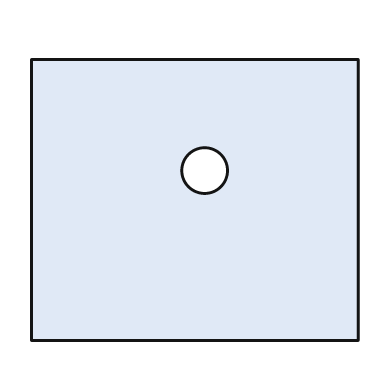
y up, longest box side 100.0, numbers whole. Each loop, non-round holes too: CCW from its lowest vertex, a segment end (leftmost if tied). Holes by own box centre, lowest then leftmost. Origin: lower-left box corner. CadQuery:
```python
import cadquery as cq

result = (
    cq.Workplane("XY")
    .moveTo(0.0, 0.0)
    .lineTo(100.0, 0.0)
    .lineTo(100.0, 86.0)
    .lineTo(0.0, 86.0)
    .close()
    .moveTo(53.0, 52.0)
    .circle(7.0)
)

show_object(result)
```